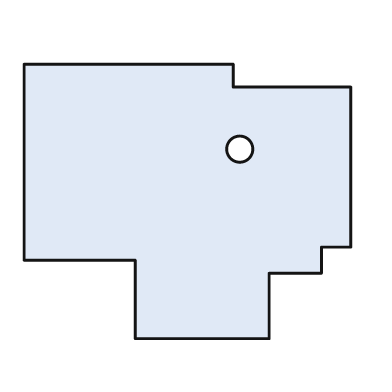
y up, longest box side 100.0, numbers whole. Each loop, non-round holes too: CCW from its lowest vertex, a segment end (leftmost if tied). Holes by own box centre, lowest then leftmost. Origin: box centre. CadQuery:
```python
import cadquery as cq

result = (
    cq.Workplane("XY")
    .moveTo(-16.0, -42.0)
    .lineTo(25.0, -42.0)
    .lineTo(25.0, -22.0)
    .lineTo(41.0, -22.0)
    .lineTo(41.0, -14.0)
    .lineTo(50.0, -14.0)
    .lineTo(50.0, 35.0)
    .lineTo(14.0, 35.0)
    .lineTo(14.0, 42.0)
    .lineTo(-50.0, 42.0)
    .lineTo(-50.0, -18.0)
    .lineTo(-16.0, -18.0)
    .close()
    .moveTo(16.0, 16.0)
    .circle(4.0)
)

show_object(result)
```